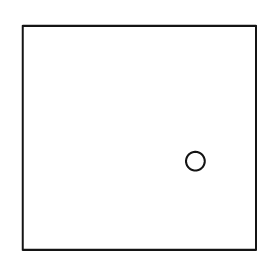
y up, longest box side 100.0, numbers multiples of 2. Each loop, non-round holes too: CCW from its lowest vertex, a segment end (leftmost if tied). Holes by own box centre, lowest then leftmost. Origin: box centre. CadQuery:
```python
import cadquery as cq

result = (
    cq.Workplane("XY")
    .moveTo(-50.0, -48.0)
    .lineTo(50.0, -48.0)
    .lineTo(50.0, 48.0)
    .lineTo(-50.0, 48.0)
    .close()
    .moveTo(24.0, -10.0)
    .circle(4.0)
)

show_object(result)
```